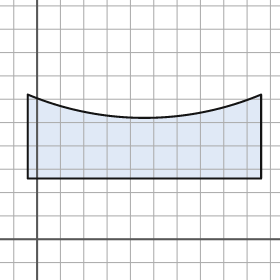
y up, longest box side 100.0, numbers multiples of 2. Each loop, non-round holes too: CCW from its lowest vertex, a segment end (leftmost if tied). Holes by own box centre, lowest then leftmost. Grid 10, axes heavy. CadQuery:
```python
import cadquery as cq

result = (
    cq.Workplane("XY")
    .moveTo(-4.0, 26.0)
    .lineTo(96.0, 26.0)
    .lineTo(96.0, 62.0)
    .threePointArc((46.0, 52.0), (-4.0, 62.0))
    .close()
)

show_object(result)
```